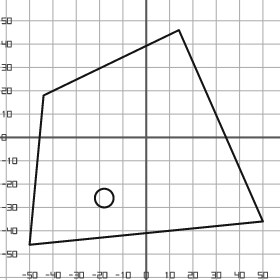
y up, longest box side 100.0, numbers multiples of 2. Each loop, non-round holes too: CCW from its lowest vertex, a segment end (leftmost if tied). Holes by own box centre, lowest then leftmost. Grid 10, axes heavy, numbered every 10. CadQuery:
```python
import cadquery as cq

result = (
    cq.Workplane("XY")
    .moveTo(-50.0, -46.0)
    .lineTo(50.0, -36.0)
    .lineTo(14.0, 46.0)
    .lineTo(-44.0, 18.0)
    .close()
    .moveTo(-18.0, -26.0)
    .circle(4.0)
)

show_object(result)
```